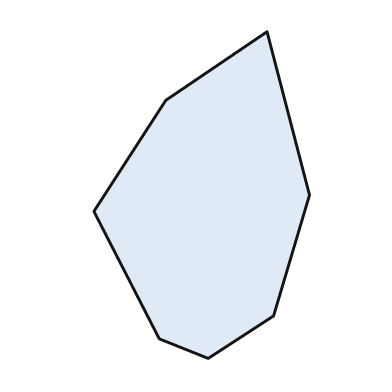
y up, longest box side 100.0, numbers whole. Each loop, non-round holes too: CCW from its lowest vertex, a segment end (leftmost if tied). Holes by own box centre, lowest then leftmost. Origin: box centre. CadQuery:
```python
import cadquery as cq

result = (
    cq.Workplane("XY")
    .moveTo(2.0, -50.0)
    .lineTo(22.0, -37.0)
    .lineTo(33.0, 0.0)
    .lineTo(20.0, 50.0)
    .lineTo(-11.0, 29.0)
    .lineTo(-33.0, -5.0)
    .lineTo(-13.0, -44.0)
    .close()
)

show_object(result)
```